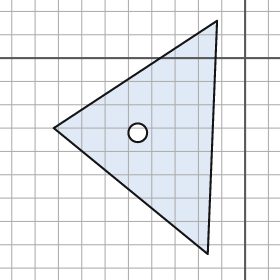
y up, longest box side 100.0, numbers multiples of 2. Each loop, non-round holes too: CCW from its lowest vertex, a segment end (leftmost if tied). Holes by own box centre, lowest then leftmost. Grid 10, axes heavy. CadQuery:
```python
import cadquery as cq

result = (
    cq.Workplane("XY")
    .moveTo(-16.0, -84.0)
    .lineTo(-12.0, 16.0)
    .lineTo(-82.0, -30.0)
    .close()
    .moveTo(-46.0, -32.0)
    .circle(4.0)
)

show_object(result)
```